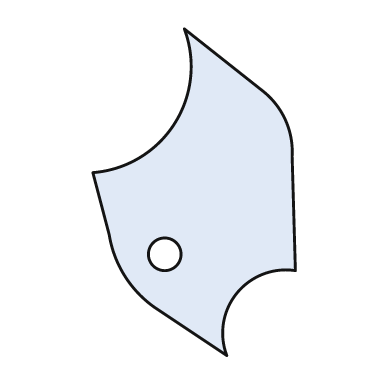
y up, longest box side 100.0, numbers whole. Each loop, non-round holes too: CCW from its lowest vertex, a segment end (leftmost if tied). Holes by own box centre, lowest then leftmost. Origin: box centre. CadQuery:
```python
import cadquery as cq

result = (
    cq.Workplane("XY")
    .moveTo(10.0, -50.0)
    .threePointArc((13.0, -31.0), (31.0, -24.0))
    .lineTo(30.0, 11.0)
    .threePointArc((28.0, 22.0), (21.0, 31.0))
    .lineTo(-3.0, 50.0)
    .threePointArc((-6.0, 21.0), (-31.0, 6.0))
    .lineTo(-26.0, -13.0)
    .threePointArc((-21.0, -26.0), (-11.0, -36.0))
    .close()
    .moveTo(-9.0, -19.0)
    .circle(5.0)
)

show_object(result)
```